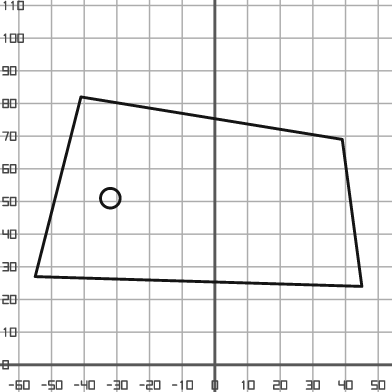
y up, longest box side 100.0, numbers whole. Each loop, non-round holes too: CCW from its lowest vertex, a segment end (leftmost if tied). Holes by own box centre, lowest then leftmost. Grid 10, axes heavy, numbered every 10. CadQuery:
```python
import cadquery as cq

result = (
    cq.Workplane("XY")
    .moveTo(45.0, 24.0)
    .lineTo(39.0, 69.0)
    .lineTo(-41.0, 82.0)
    .lineTo(-55.0, 27.0)
    .close()
    .moveTo(-32.0, 51.0)
    .circle(3.0)
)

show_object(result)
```